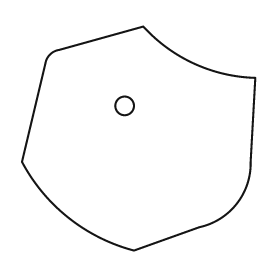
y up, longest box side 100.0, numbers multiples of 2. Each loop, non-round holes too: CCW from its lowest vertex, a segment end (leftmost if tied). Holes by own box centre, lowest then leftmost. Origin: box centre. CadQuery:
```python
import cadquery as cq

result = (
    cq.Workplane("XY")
    .moveTo(-2.0, -48.0)
    .lineTo(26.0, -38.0)
    .threePointArc((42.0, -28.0), (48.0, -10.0))
    .lineTo(50.0, 26.0)
    .threePointArc((24.0, 32.0), (2.0, 48.0))
    .lineTo(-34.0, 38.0)
    .threePointArc((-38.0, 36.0), (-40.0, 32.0))
    .lineTo(-50.0, -10.0)
    .threePointArc((-30.0, -34.0), (-2.0, -48.0))
    .close()
    .moveTo(-6.0, 14.0)
    .circle(4.0)
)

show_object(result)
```